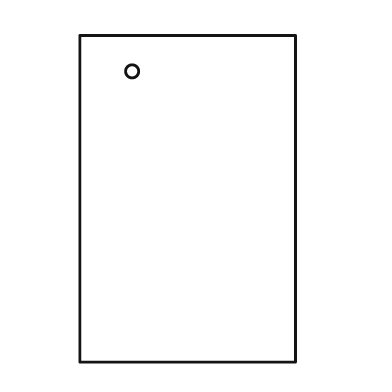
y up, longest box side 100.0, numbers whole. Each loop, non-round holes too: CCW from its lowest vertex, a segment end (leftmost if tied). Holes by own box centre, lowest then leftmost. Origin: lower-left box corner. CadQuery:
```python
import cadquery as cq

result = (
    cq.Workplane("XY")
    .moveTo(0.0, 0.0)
    .lineTo(66.0, 0.0)
    .lineTo(66.0, 100.0)
    .lineTo(0.0, 100.0)
    .close()
    .moveTo(16.0, 89.0)
    .circle(2.0)
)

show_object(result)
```